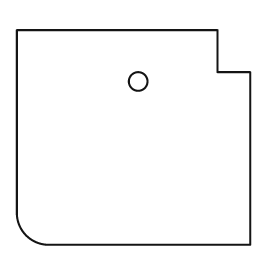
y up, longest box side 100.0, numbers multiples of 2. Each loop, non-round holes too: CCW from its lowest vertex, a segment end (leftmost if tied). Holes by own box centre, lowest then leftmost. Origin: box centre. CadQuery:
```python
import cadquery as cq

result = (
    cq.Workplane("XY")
    .moveTo(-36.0, -46.0)
    .lineTo(50.0, -46.0)
    .lineTo(50.0, 28.0)
    .lineTo(36.0, 28.0)
    .lineTo(36.0, 46.0)
    .lineTo(-50.0, 46.0)
    .lineTo(-50.0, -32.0)
    .threePointArc((-46.0, -42.0), (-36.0, -46.0))
    .close()
    .moveTo(2.0, 24.0)
    .circle(4.0)
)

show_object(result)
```